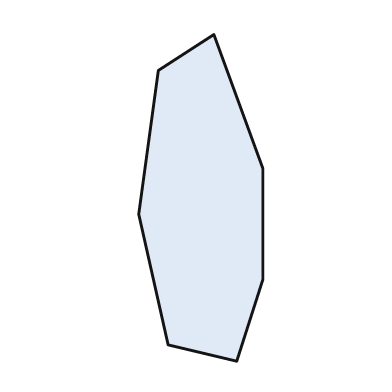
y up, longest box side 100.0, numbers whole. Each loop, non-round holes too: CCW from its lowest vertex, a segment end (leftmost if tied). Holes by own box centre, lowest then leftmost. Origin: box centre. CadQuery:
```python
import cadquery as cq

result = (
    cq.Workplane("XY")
    .moveTo(11.0, -50.0)
    .lineTo(19.0, -25.0)
    .lineTo(19.0, 9.0)
    .lineTo(4.0, 50.0)
    .lineTo(-13.0, 39.0)
    .lineTo(-19.0, -5.0)
    .lineTo(-10.0, -45.0)
    .close()
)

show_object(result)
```